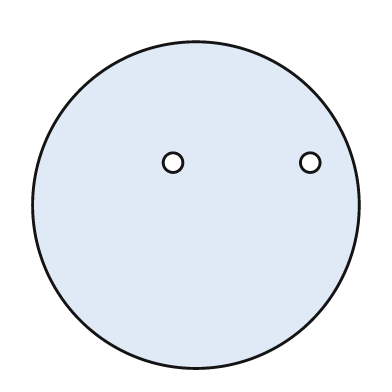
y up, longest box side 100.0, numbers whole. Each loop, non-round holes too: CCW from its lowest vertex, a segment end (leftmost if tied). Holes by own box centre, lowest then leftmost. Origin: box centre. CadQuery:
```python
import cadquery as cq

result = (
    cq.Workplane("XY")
    .moveTo(0.0, 0.0)
    .circle(50.0)
    .moveTo(-7.0, 13.0)
    .circle(3.0)
    .moveTo(35.0, 13.0)
    .circle(3.0)
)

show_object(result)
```